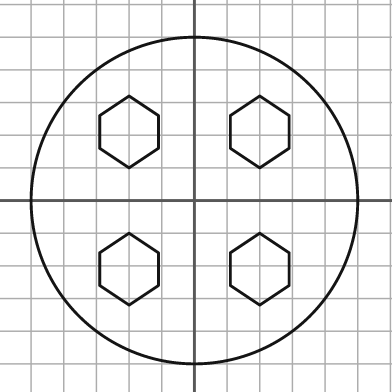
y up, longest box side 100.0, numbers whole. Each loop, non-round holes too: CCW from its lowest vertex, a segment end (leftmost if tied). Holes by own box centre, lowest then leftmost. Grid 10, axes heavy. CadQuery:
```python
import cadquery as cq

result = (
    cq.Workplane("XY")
    .moveTo(0.0, 0.0)
    .circle(50.0)
    .moveTo(-20.0, -32.0)
    .lineTo(-11.0, -26.0)
    .lineTo(-11.0, -16.0)
    .lineTo(-20.0, -10.0)
    .lineTo(-29.0, -16.0)
    .lineTo(-29.0, -26.0)
    .close()
    .moveTo(20.0, -32.0)
    .lineTo(29.0, -26.0)
    .lineTo(29.0, -16.0)
    .lineTo(20.0, -10.0)
    .lineTo(11.0, -16.0)
    .lineTo(11.0, -26.0)
    .close()
    .moveTo(-20.0, 10.0)
    .lineTo(-11.0, 16.0)
    .lineTo(-11.0, 26.0)
    .lineTo(-20.0, 32.0)
    .lineTo(-29.0, 26.0)
    .lineTo(-29.0, 16.0)
    .close()
    .moveTo(20.0, 10.0)
    .lineTo(29.0, 16.0)
    .lineTo(29.0, 26.0)
    .lineTo(20.0, 32.0)
    .lineTo(11.0, 26.0)
    .lineTo(11.0, 16.0)
    .close()
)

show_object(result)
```